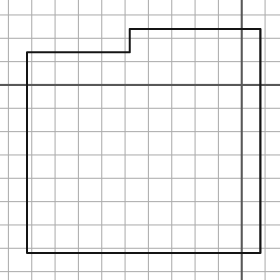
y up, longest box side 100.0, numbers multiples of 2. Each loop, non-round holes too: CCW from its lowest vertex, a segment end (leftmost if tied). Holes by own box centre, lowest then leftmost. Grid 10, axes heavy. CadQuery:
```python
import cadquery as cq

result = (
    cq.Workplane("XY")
    .moveTo(-92.0, -72.0)
    .lineTo(8.0, -72.0)
    .lineTo(8.0, 24.0)
    .lineTo(-48.0, 24.0)
    .lineTo(-48.0, 14.0)
    .lineTo(-92.0, 14.0)
    .close()
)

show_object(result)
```